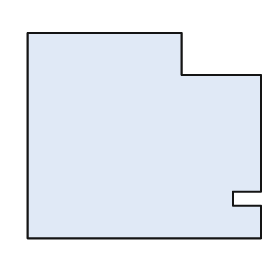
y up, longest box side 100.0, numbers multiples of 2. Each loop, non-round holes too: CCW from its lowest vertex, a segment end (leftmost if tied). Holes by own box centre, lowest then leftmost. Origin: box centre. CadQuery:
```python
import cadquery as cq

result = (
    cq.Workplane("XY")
    .moveTo(-50.0, -44.0)
    .lineTo(50.0, -44.0)
    .lineTo(50.0, -30.0)
    .lineTo(38.0, -30.0)
    .lineTo(38.0, -24.0)
    .lineTo(50.0, -24.0)
    .lineTo(50.0, 26.0)
    .lineTo(16.0, 26.0)
    .lineTo(16.0, 44.0)
    .lineTo(-50.0, 44.0)
    .close()
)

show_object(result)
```